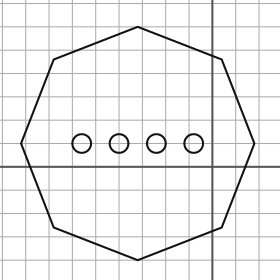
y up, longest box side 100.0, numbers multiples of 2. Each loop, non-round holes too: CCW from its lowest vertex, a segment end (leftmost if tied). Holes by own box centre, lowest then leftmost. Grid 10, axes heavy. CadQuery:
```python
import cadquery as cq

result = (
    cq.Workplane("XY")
    .moveTo(-32.0, -40.0)
    .lineTo(4.0, -26.0)
    .lineTo(18.0, 10.0)
    .lineTo(4.0, 46.0)
    .lineTo(-32.0, 60.0)
    .lineTo(-68.0, 46.0)
    .lineTo(-82.0, 10.0)
    .lineTo(-68.0, -26.0)
    .close()
    .moveTo(-56.0, 10.0)
    .circle(4.0)
    .moveTo(-40.0, 10.0)
    .circle(4.0)
    .moveTo(-24.0, 10.0)
    .circle(4.0)
    .moveTo(-8.0, 10.0)
    .circle(4.0)
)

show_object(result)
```